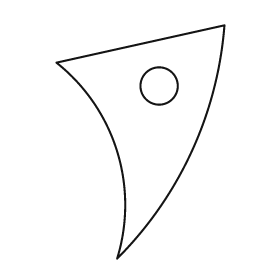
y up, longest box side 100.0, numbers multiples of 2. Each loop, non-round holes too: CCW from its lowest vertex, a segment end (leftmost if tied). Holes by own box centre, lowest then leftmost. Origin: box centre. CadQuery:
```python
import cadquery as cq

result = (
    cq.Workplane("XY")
    .moveTo(-10.0, -50.0)
    .threePointArc((22.0, -4.0), (36.0, 50.0))
    .lineTo(-36.0, 34.0)
    .threePointArc((-10.0, -4.0), (-10.0, -50.0))
    .close()
    .moveTo(8.0, 24.0)
    .circle(8.0)
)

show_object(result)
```